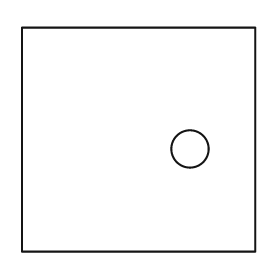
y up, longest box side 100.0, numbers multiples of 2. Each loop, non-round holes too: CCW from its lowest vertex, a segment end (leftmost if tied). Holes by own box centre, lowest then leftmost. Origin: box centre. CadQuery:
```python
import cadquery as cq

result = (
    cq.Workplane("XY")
    .moveTo(-50.0, -48.0)
    .lineTo(50.0, -48.0)
    .lineTo(50.0, 48.0)
    .lineTo(-50.0, 48.0)
    .close()
    .moveTo(22.0, -4.0)
    .circle(8.0)
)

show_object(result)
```